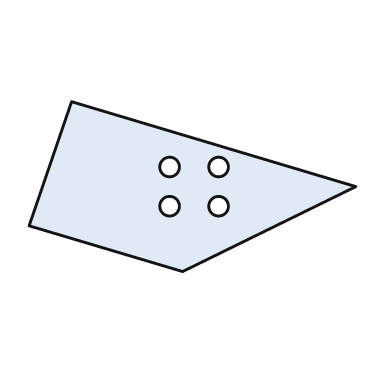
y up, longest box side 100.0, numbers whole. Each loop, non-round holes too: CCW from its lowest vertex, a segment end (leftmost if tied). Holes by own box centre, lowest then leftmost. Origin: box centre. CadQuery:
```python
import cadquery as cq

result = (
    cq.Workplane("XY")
    .moveTo(-3.0, -26.0)
    .lineTo(50.0, 0.0)
    .lineTo(-37.0, 26.0)
    .lineTo(-50.0, -12.0)
    .close()
    .moveTo(-7.0, -6.0)
    .circle(3.0)
    .moveTo(8.0, -6.0)
    .circle(3.0)
    .moveTo(-7.0, 6.0)
    .circle(3.0)
    .moveTo(8.0, 6.0)
    .circle(3.0)
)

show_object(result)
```